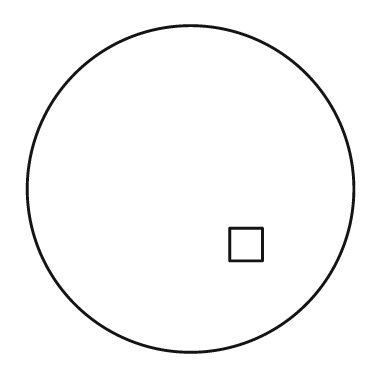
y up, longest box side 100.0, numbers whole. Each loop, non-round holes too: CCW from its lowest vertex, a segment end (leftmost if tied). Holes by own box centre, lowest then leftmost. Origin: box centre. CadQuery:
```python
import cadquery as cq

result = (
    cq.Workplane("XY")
    .moveTo(0.0, 0.0)
    .circle(50.0)
    .moveTo(12.0, -22.0)
    .lineTo(22.0, -22.0)
    .lineTo(22.0, -12.0)
    .lineTo(12.0, -12.0)
    .close()
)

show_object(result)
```